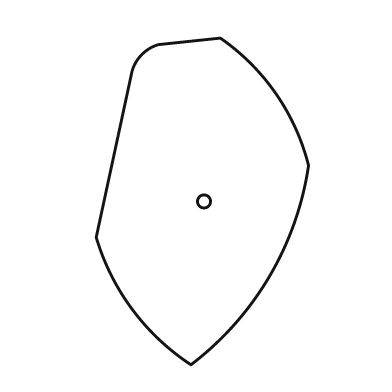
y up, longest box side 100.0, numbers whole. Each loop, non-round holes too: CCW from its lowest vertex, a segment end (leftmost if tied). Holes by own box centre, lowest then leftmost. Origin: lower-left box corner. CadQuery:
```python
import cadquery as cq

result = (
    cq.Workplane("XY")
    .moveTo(29.0, 0.0)
    .threePointArc((53.0, 27.0), (65.0, 61.0))
    .threePointArc((55.0, 83.0), (38.0, 100.0))
    .lineTo(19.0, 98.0)
    .threePointArc((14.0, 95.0), (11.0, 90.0))
    .lineTo(0.0, 39.0)
    .threePointArc((11.0, 17.0), (29.0, 0.0))
    .close()
    .moveTo(33.0, 50.0)
    .circle(2.0)
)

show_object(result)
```